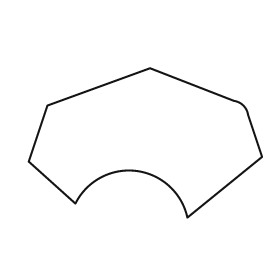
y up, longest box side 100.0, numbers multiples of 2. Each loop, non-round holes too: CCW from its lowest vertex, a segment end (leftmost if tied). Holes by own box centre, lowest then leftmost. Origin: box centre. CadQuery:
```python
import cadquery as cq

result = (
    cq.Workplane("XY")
    .moveTo(18.0, -32.0)
    .lineTo(50.0, -6.0)
    .lineTo(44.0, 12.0)
    .threePointArc((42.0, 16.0), (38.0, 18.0))
    .lineTo(2.0, 32.0)
    .lineTo(-42.0, 16.0)
    .lineTo(-50.0, -8.0)
    .lineTo(-30.0, -26.0)
    .threePointArc((-4.0, -12.0), (18.0, -32.0))
    .close()
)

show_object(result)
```